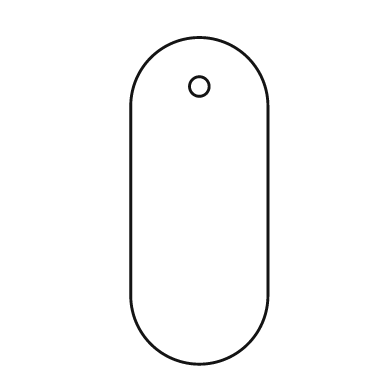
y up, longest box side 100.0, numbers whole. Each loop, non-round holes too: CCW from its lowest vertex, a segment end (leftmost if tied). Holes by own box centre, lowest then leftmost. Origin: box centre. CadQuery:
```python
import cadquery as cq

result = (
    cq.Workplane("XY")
    .moveTo(-21.0, -29.0)
    .threePointArc((0.0, -50.0), (21.0, -29.0))
    .lineTo(21.0, 29.0)
    .threePointArc((0.0, 50.0), (-21.0, 29.0))
    .close()
    .moveTo(0.0, 35.0)
    .circle(3.0)
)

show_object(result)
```